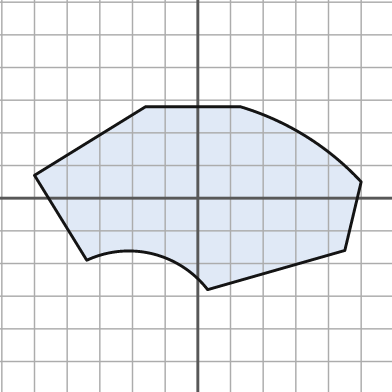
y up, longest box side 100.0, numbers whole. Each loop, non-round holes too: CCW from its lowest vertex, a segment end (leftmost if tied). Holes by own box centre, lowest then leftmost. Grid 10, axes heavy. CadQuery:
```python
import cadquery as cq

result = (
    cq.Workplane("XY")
    .moveTo(3.0, -28.0)
    .lineTo(45.0, -16.0)
    .lineTo(50.0, 5.0)
    .threePointArc((33.0, 19.0), (13.0, 28.0))
    .lineTo(-16.0, 28.0)
    .lineTo(-50.0, 7.0)
    .lineTo(-34.0, -19.0)
    .threePointArc((-14.0, -17.0), (3.0, -28.0))
    .close()
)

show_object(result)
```